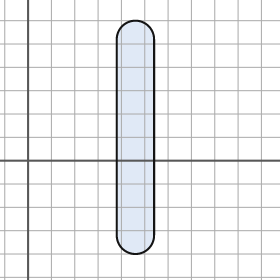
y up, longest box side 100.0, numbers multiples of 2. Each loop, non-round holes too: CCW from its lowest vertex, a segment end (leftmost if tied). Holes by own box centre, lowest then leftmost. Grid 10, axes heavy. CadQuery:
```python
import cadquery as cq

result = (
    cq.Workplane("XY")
    .moveTo(38.0, -32.0)
    .threePointArc((46.0, -40.0), (54.0, -32.0))
    .lineTo(54.0, 52.0)
    .threePointArc((46.0, 60.0), (38.0, 52.0))
    .close()
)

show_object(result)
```